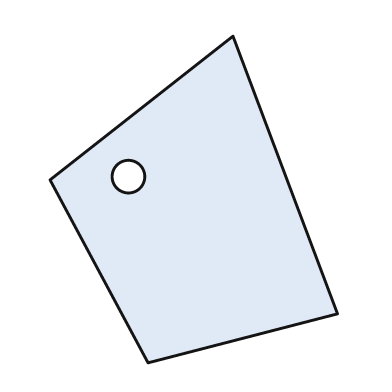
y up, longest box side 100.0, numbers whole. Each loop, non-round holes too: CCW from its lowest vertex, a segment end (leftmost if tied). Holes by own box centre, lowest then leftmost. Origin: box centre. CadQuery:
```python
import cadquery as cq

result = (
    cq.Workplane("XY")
    .moveTo(-14.0, -50.0)
    .lineTo(44.0, -35.0)
    .lineTo(12.0, 50.0)
    .lineTo(-44.0, 6.0)
    .close()
    .moveTo(-20.0, 7.0)
    .circle(5.0)
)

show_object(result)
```